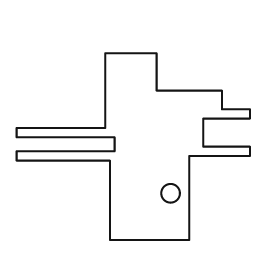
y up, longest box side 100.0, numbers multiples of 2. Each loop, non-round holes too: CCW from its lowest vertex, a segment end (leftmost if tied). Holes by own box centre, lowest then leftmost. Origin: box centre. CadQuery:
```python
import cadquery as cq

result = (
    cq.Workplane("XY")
    .moveTo(-10.0, -40.0)
    .lineTo(24.0, -40.0)
    .lineTo(24.0, -4.0)
    .lineTo(50.0, -4.0)
    .lineTo(50.0, 0.0)
    .lineTo(30.0, 0.0)
    .lineTo(30.0, 12.0)
    .lineTo(50.0, 12.0)
    .lineTo(50.0, 16.0)
    .lineTo(38.0, 16.0)
    .lineTo(38.0, 24.0)
    .lineTo(10.0, 24.0)
    .lineTo(10.0, 40.0)
    .lineTo(-12.0, 40.0)
    .lineTo(-12.0, 8.0)
    .lineTo(-50.0, 8.0)
    .lineTo(-50.0, 4.0)
    .lineTo(-8.0, 4.0)
    .lineTo(-8.0, -2.0)
    .lineTo(-50.0, -2.0)
    .lineTo(-50.0, -6.0)
    .lineTo(-10.0, -6.0)
    .close()
    .moveTo(16.0, -20.0)
    .circle(4.0)
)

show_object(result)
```